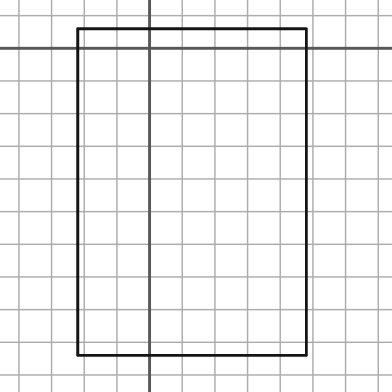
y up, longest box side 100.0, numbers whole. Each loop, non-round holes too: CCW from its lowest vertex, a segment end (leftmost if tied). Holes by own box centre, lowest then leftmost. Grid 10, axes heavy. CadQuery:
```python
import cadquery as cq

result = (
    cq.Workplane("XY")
    .moveTo(-22.0, -94.0)
    .lineTo(48.0, -94.0)
    .lineTo(48.0, 6.0)
    .lineTo(-22.0, 6.0)
    .close()
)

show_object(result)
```